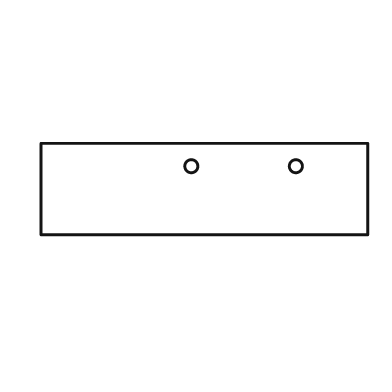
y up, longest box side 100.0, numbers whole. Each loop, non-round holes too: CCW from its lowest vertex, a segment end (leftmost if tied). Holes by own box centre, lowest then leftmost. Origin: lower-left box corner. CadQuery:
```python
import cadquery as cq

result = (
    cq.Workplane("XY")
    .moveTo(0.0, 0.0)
    .lineTo(100.0, 0.0)
    .lineTo(100.0, 28.0)
    .lineTo(0.0, 28.0)
    .close()
    .moveTo(46.0, 21.0)
    .circle(2.0)
    .moveTo(78.0, 21.0)
    .circle(2.0)
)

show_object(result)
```